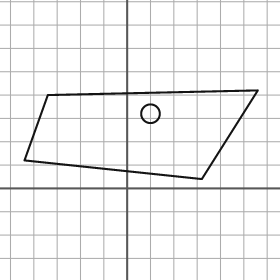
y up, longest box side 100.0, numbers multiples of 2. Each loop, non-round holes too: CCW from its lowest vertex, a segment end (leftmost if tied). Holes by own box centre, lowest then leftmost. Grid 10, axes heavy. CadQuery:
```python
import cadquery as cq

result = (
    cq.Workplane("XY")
    .moveTo(32.0, 4.0)
    .lineTo(56.0, 42.0)
    .lineTo(-34.0, 40.0)
    .lineTo(-44.0, 12.0)
    .close()
    .moveTo(10.0, 32.0)
    .circle(4.0)
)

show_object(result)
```